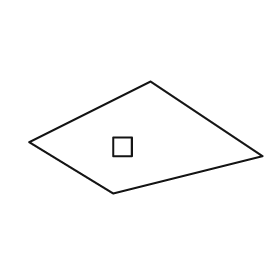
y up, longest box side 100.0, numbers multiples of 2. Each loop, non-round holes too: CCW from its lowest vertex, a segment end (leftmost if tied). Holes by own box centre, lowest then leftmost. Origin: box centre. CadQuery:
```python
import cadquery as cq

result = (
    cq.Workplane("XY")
    .moveTo(-14.0, -24.0)
    .lineTo(50.0, -8.0)
    .lineTo(2.0, 24.0)
    .lineTo(-50.0, -2.0)
    .close()
    .moveTo(-14.0, -8.0)
    .lineTo(-6.0, -8.0)
    .lineTo(-6.0, 0.0)
    .lineTo(-14.0, 0.0)
    .close()
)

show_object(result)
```